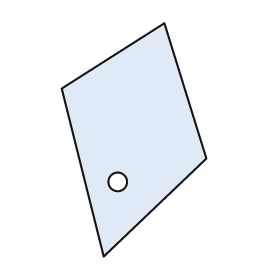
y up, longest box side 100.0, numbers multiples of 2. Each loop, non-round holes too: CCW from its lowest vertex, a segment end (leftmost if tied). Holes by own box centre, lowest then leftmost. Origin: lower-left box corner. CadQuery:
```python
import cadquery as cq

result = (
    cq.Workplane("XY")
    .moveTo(18.0, 0.0)
    .lineTo(62.0, 42.0)
    .lineTo(44.0, 100.0)
    .lineTo(0.0, 72.0)
    .close()
    .moveTo(24.0, 32.0)
    .circle(4.0)
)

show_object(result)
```